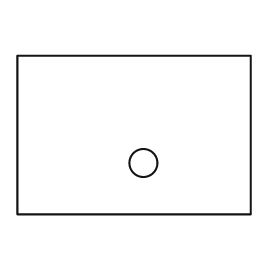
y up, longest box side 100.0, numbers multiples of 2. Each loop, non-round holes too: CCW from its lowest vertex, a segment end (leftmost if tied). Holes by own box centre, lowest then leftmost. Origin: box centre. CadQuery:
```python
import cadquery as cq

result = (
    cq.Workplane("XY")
    .moveTo(-50.0, -34.0)
    .lineTo(50.0, -34.0)
    .lineTo(50.0, 34.0)
    .lineTo(-50.0, 34.0)
    .close()
    .moveTo(4.0, -12.0)
    .circle(6.0)
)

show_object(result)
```